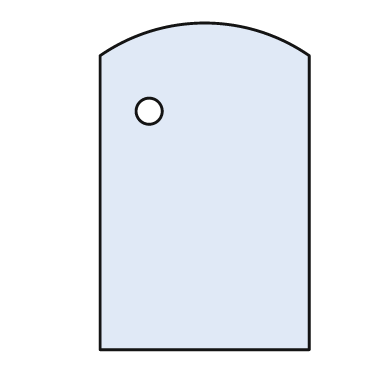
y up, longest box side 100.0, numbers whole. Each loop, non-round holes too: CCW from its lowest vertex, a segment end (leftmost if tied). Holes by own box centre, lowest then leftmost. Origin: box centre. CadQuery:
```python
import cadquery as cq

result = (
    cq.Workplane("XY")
    .moveTo(-32.0, -50.0)
    .lineTo(32.0, -50.0)
    .lineTo(32.0, 40.0)
    .threePointArc((0.0, 50.0), (-32.0, 40.0))
    .close()
    .moveTo(-17.0, 23.0)
    .circle(4.0)
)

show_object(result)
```